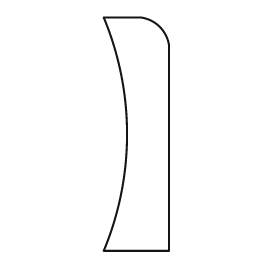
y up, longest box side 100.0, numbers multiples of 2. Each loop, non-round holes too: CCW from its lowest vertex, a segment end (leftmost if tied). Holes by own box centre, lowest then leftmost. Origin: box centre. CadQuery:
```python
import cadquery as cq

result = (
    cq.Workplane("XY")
    .moveTo(-14.0, -50.0)
    .lineTo(14.0, -50.0)
    .lineTo(14.0, 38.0)
    .threePointArc((10.0, 46.0), (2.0, 50.0))
    .lineTo(-14.0, 50.0)
    .threePointArc((-4.0, 0.0), (-14.0, -50.0))
    .close()
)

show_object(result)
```